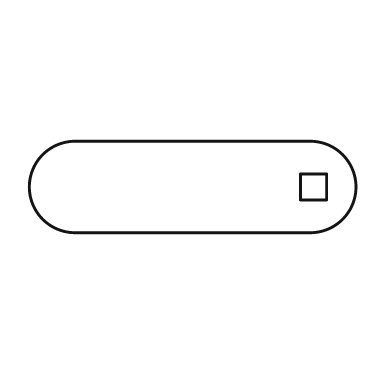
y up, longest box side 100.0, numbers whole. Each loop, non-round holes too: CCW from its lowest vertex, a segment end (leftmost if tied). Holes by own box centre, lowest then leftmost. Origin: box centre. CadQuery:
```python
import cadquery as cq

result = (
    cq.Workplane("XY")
    .moveTo(-36.0, -14.0)
    .lineTo(36.0, -14.0)
    .threePointArc((50.0, 0.0), (36.0, 14.0))
    .lineTo(-36.0, 14.0)
    .threePointArc((-50.0, 0.0), (-36.0, -14.0))
    .close()
    .moveTo(33.0, -4.0)
    .lineTo(41.0, -4.0)
    .lineTo(41.0, 4.0)
    .lineTo(33.0, 4.0)
    .close()
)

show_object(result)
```